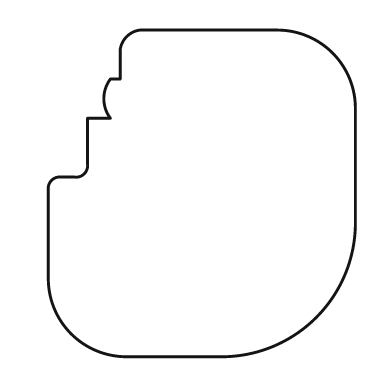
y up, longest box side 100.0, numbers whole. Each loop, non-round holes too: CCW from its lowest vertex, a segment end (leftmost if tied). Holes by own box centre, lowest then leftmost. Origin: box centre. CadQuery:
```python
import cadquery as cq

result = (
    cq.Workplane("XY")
    .moveTo(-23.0, -50.0)
    .lineTo(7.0, -50.0)
    .threePointArc((35.0, -38.0), (47.0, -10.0))
    .lineTo(47.0, 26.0)
    .threePointArc((40.0, 43.0), (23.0, 50.0))
    .lineTo(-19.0, 50.0)
    .threePointArc((-23.0, 48.0), (-25.0, 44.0))
    .lineTo(-25.0, 35.0)
    .lineTo(-28.0, 35.0)
    .threePointArc((-30.0, 29.0), (-28.0, 23.0))
    .lineTo(-35.0, 23.0)
    .lineTo(-35.0, 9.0)
    .threePointArc((-36.0, 6.0), (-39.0, 5.0))
    .lineTo(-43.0, 5.0)
    .threePointArc((-46.0, 4.0), (-47.0, 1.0))
    .lineTo(-47.0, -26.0)
    .threePointArc((-40.0, -43.0), (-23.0, -50.0))
    .close()
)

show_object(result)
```